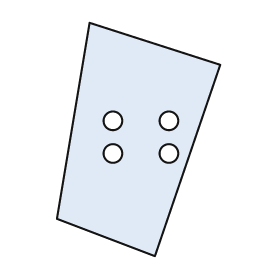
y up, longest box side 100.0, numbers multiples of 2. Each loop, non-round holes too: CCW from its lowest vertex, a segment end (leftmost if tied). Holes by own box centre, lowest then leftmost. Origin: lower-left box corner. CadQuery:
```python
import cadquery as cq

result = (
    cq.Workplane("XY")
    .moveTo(42.0, 0.0)
    .lineTo(70.0, 82.0)
    .lineTo(14.0, 100.0)
    .lineTo(0.0, 16.0)
    .close()
    .moveTo(24.0, 44.0)
    .circle(4.0)
    .moveTo(48.0, 44.0)
    .circle(4.0)
    .moveTo(24.0, 58.0)
    .circle(4.0)
    .moveTo(48.0, 58.0)
    .circle(4.0)
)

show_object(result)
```